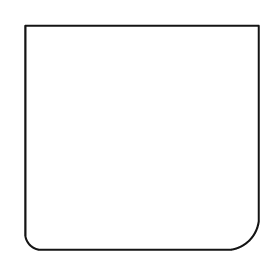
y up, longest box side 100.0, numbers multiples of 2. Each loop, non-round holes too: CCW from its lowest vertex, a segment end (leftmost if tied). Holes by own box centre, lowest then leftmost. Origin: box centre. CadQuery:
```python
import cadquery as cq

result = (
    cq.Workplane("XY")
    .moveTo(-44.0, -48.0)
    .lineTo(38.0, -48.0)
    .threePointArc((46.0, -44.0), (50.0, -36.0))
    .lineTo(50.0, 48.0)
    .lineTo(-50.0, 48.0)
    .lineTo(-50.0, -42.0)
    .threePointArc((-48.0, -46.0), (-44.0, -48.0))
    .close()
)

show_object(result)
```